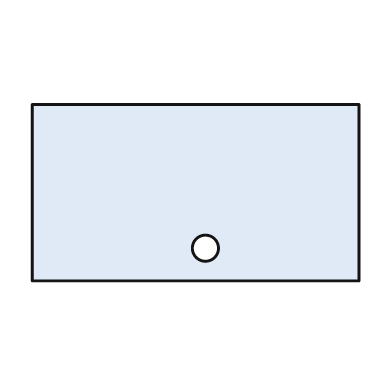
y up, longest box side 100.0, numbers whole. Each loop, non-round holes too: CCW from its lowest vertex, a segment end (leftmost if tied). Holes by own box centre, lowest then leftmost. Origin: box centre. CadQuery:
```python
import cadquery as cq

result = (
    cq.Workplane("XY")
    .moveTo(-50.0, -27.0)
    .lineTo(50.0, -27.0)
    .lineTo(50.0, 27.0)
    .lineTo(-50.0, 27.0)
    .close()
    .moveTo(3.0, -17.0)
    .circle(4.0)
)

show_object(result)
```